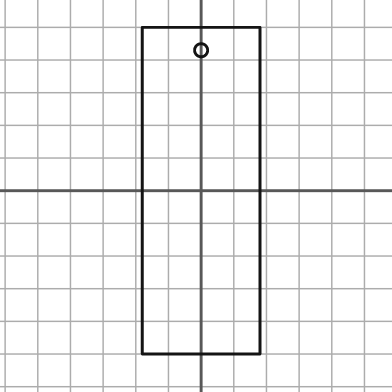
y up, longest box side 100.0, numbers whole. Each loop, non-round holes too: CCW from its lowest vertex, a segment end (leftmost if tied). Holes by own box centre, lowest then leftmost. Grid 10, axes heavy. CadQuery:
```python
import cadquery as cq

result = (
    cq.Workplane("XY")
    .moveTo(-18.0, -50.0)
    .lineTo(18.0, -50.0)
    .lineTo(18.0, 50.0)
    .lineTo(-18.0, 50.0)
    .close()
    .moveTo(0.0, 43.0)
    .circle(2.0)
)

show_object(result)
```